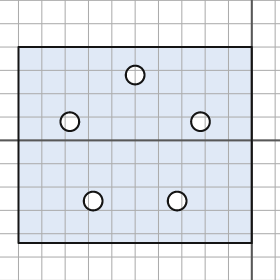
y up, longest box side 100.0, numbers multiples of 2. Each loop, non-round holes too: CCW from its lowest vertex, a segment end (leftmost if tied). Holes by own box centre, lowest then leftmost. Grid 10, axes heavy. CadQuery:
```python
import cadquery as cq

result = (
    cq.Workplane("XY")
    .moveTo(-100.0, -44.0)
    .lineTo(0.0, -44.0)
    .lineTo(0.0, 40.0)
    .lineTo(-100.0, 40.0)
    .close()
    .moveTo(-68.0, -26.0)
    .circle(4.0)
    .moveTo(-32.0, -26.0)
    .circle(4.0)
    .moveTo(-78.0, 8.0)
    .circle(4.0)
    .moveTo(-22.0, 8.0)
    .circle(4.0)
    .moveTo(-50.0, 28.0)
    .circle(4.0)
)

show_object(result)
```